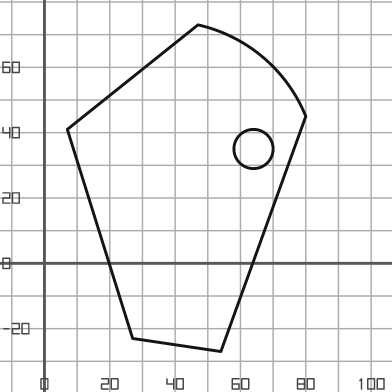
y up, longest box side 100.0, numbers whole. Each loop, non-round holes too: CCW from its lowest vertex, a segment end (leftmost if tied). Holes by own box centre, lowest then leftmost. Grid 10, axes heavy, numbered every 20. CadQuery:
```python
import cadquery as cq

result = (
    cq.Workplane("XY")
    .moveTo(54.0, -27.0)
    .lineTo(80.0, 45.0)
    .threePointArc((67.0, 63.0), (47.0, 73.0))
    .lineTo(7.0, 41.0)
    .lineTo(27.0, -23.0)
    .close()
    .moveTo(64.0, 35.0)
    .circle(6.0)
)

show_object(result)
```